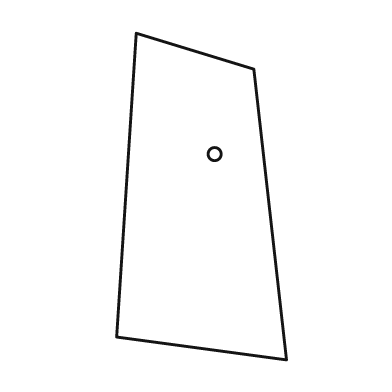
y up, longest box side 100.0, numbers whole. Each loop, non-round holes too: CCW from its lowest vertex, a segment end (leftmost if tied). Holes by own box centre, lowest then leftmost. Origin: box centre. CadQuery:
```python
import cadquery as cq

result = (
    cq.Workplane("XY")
    .moveTo(26.0, -50.0)
    .lineTo(16.0, 39.0)
    .lineTo(-20.0, 50.0)
    .lineTo(-26.0, -43.0)
    .close()
    .moveTo(4.0, 13.0)
    .circle(2.0)
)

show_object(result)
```